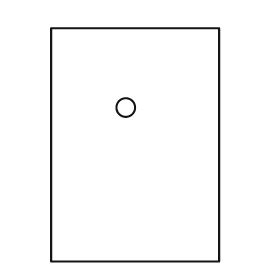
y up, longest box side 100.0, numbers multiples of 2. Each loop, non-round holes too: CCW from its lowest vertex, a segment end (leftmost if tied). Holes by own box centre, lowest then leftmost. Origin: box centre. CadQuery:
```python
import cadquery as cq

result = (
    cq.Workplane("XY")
    .moveTo(-36.0, -50.0)
    .lineTo(36.0, -50.0)
    .lineTo(36.0, 50.0)
    .lineTo(-36.0, 50.0)
    .close()
    .moveTo(-4.0, 16.0)
    .circle(4.0)
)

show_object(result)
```